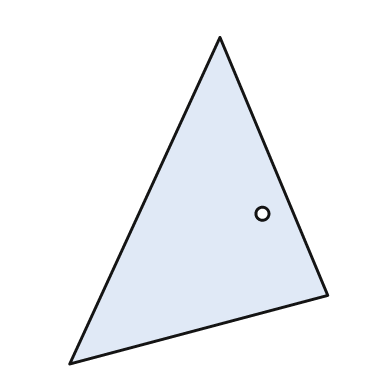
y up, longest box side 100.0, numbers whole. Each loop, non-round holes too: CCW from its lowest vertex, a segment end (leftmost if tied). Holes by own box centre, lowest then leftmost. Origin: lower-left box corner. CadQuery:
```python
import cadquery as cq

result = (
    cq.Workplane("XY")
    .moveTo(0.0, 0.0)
    .lineTo(79.0, 21.0)
    .lineTo(46.0, 100.0)
    .close()
    .moveTo(59.0, 46.0)
    .circle(2.0)
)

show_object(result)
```